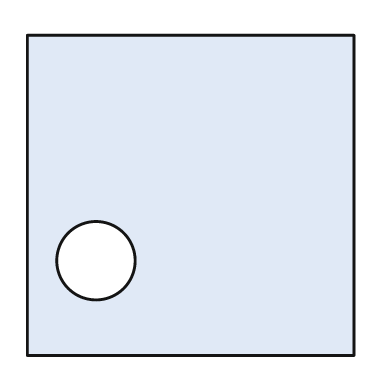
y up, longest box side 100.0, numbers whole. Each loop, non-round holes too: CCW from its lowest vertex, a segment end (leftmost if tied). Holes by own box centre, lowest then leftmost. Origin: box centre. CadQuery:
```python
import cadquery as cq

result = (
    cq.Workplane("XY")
    .moveTo(-50.0, -49.0)
    .lineTo(50.0, -49.0)
    .lineTo(50.0, 49.0)
    .lineTo(-50.0, 49.0)
    .close()
    .moveTo(-29.0, -20.0)
    .circle(12.0)
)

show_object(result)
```